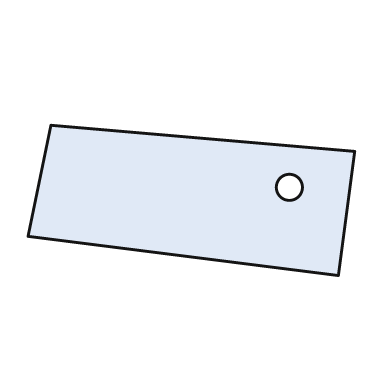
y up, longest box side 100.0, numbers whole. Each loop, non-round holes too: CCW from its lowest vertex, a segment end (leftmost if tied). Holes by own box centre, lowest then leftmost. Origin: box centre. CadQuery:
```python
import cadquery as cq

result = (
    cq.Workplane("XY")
    .moveTo(45.0, -23.0)
    .lineTo(50.0, 15.0)
    .lineTo(-43.0, 23.0)
    .lineTo(-50.0, -11.0)
    .close()
    .moveTo(30.0, 4.0)
    .circle(4.0)
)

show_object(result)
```